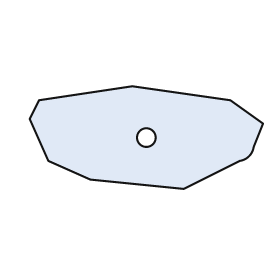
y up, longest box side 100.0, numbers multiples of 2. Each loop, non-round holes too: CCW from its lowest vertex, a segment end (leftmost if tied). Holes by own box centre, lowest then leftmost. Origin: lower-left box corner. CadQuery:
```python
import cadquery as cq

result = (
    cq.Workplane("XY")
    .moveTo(66.0, 0.0)
    .lineTo(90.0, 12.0)
    .threePointArc((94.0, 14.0), (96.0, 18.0))
    .lineTo(100.0, 28.0)
    .lineTo(86.0, 38.0)
    .lineTo(44.0, 44.0)
    .lineTo(4.0, 38.0)
    .lineTo(0.0, 30.0)
    .lineTo(8.0, 12.0)
    .lineTo(26.0, 4.0)
    .close()
    .moveTo(50.0, 22.0)
    .circle(4.0)
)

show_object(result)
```